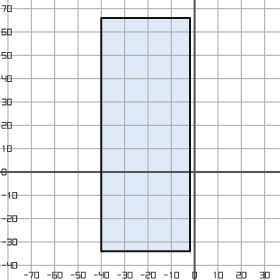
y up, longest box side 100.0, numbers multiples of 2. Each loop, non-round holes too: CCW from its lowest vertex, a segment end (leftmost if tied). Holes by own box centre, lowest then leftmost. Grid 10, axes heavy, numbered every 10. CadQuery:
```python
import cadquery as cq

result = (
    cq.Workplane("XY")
    .moveTo(-40.0, -34.0)
    .lineTo(-2.0, -34.0)
    .lineTo(-2.0, 66.0)
    .lineTo(-40.0, 66.0)
    .close()
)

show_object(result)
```